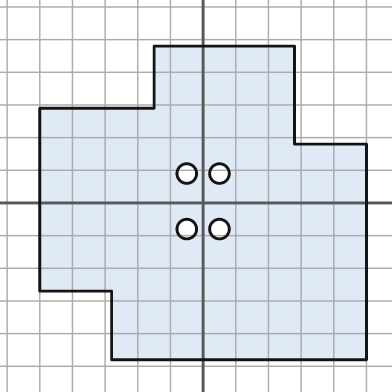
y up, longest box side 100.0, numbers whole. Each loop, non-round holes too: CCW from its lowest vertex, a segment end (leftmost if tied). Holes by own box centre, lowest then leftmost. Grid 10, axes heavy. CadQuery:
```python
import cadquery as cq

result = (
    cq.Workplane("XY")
    .moveTo(-28.0, -48.0)
    .lineTo(50.0, -48.0)
    .lineTo(50.0, 18.0)
    .lineTo(28.0, 18.0)
    .lineTo(28.0, 48.0)
    .lineTo(-15.0, 48.0)
    .lineTo(-15.0, 29.0)
    .lineTo(-50.0, 29.0)
    .lineTo(-50.0, -27.0)
    .lineTo(-28.0, -27.0)
    .close()
    .moveTo(-5.0, -8.0)
    .circle(3.0)
    .moveTo(5.0, -8.0)
    .circle(3.0)
    .moveTo(-5.0, 9.0)
    .circle(3.0)
    .moveTo(5.0, 9.0)
    .circle(3.0)
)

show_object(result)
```